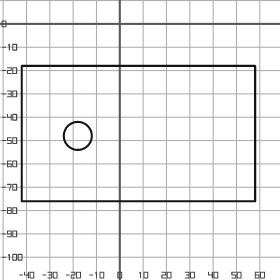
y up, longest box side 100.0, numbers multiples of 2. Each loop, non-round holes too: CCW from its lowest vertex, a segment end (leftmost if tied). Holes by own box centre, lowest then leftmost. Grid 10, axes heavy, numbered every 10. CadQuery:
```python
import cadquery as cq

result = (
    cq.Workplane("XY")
    .moveTo(-42.0, -76.0)
    .lineTo(58.0, -76.0)
    .lineTo(58.0, -18.0)
    .lineTo(-42.0, -18.0)
    .close()
    .moveTo(-18.0, -48.0)
    .circle(6.0)
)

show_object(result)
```